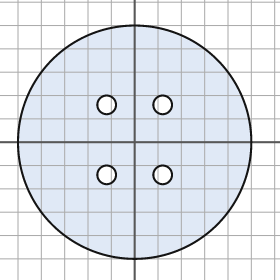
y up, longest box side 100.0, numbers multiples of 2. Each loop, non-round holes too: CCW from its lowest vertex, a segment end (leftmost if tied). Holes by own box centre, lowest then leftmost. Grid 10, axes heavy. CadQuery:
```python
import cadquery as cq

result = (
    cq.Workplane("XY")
    .moveTo(0.0, 0.0)
    .circle(50.0)
    .moveTo(-12.0, -14.0)
    .circle(4.0)
    .moveTo(12.0, -14.0)
    .circle(4.0)
    .moveTo(-12.0, 16.0)
    .circle(4.0)
    .moveTo(12.0, 16.0)
    .circle(4.0)
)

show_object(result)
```